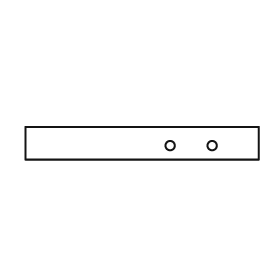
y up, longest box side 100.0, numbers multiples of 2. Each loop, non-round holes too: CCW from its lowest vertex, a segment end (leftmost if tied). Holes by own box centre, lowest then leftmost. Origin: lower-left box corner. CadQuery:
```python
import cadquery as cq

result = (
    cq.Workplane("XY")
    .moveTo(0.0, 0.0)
    .lineTo(100.0, 0.0)
    .lineTo(100.0, 14.0)
    .lineTo(0.0, 14.0)
    .close()
    .moveTo(62.0, 6.0)
    .circle(2.0)
    .moveTo(80.0, 6.0)
    .circle(2.0)
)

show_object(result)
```